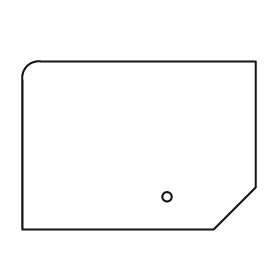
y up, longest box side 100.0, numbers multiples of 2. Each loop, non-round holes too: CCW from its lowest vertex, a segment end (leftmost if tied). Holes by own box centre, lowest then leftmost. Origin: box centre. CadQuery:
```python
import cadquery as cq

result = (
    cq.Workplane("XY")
    .moveTo(-50.0, -36.0)
    .lineTo(32.0, -36.0)
    .lineTo(50.0, -18.0)
    .lineTo(50.0, 36.0)
    .lineTo(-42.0, 36.0)
    .threePointArc((-48.0, 34.0), (-50.0, 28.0))
    .close()
    .moveTo(12.0, -22.0)
    .circle(2.0)
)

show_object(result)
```